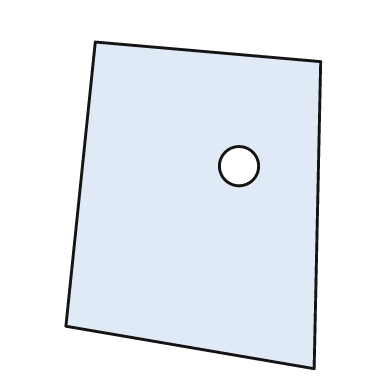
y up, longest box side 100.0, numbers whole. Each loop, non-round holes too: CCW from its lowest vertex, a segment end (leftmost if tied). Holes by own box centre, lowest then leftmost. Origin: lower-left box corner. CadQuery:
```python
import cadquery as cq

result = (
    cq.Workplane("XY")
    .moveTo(76.0, 0.0)
    .lineTo(78.0, 94.0)
    .lineTo(9.0, 100.0)
    .lineTo(0.0, 13.0)
    .close()
    .moveTo(53.0, 62.0)
    .circle(6.0)
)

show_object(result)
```